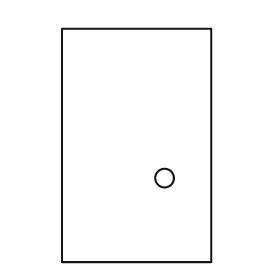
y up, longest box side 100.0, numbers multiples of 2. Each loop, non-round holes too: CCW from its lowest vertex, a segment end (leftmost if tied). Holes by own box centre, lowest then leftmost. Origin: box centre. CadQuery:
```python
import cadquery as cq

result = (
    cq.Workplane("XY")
    .moveTo(-32.0, -50.0)
    .lineTo(32.0, -50.0)
    .lineTo(32.0, 50.0)
    .lineTo(-32.0, 50.0)
    .close()
    .moveTo(12.0, -14.0)
    .circle(4.0)
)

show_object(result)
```